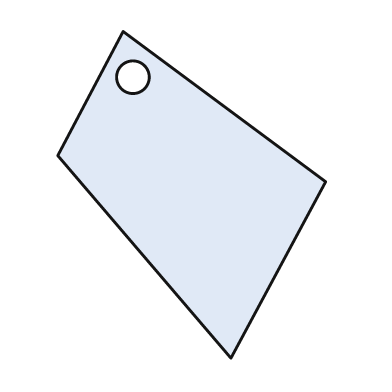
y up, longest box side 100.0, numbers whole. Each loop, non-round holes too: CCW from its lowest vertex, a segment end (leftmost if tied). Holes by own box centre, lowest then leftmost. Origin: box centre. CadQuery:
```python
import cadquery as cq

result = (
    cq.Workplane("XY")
    .moveTo(12.0, -50.0)
    .lineTo(41.0, 4.0)
    .lineTo(-21.0, 50.0)
    .lineTo(-41.0, 12.0)
    .close()
    .moveTo(-18.0, 36.0)
    .circle(5.0)
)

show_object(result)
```